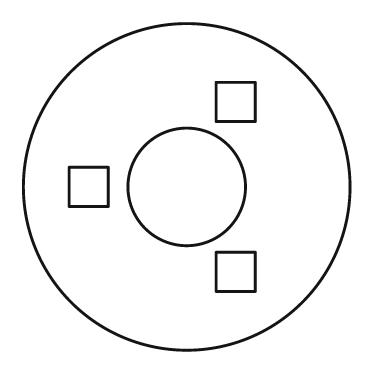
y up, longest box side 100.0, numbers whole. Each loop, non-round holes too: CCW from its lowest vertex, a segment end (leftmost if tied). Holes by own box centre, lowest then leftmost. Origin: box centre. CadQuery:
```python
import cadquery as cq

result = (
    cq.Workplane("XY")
    .moveTo(0.0, 0.0)
    .circle(50.0)
    .moveTo(9.0, -32.0)
    .lineTo(21.0, -32.0)
    .lineTo(21.0, -20.0)
    .lineTo(9.0, -20.0)
    .close()
    .moveTo(-36.0, -6.0)
    .lineTo(-24.0, -6.0)
    .lineTo(-24.0, 6.0)
    .lineTo(-36.0, 6.0)
    .close()
    .moveTo(0.0, 0.0)
    .circle(18.0)
    .moveTo(9.0, 20.0)
    .lineTo(21.0, 20.0)
    .lineTo(21.0, 32.0)
    .lineTo(9.0, 32.0)
    .close()
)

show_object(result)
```